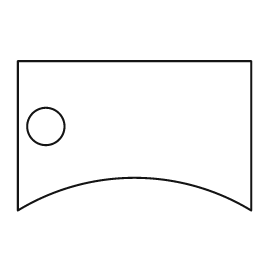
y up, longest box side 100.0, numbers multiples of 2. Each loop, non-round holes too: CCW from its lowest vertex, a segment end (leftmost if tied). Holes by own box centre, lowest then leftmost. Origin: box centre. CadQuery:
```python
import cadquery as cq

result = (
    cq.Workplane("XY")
    .moveTo(-50.0, -32.0)
    .threePointArc((0.0, -18.0), (50.0, -32.0))
    .lineTo(50.0, 32.0)
    .lineTo(-50.0, 32.0)
    .close()
    .moveTo(-38.0, 4.0)
    .circle(8.0)
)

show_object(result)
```